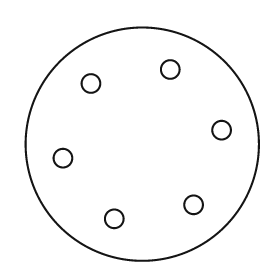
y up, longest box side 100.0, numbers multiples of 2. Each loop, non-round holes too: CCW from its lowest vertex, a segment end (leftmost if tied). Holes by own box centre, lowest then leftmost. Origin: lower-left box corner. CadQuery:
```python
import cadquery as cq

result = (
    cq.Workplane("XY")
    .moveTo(50.0, 50.0)
    .circle(50.0)
    .moveTo(38.0, 18.0)
    .circle(4.0)
    .moveTo(72.0, 24.0)
    .circle(4.0)
    .moveTo(16.0, 44.0)
    .circle(4.0)
    .moveTo(84.0, 56.0)
    .circle(4.0)
    .moveTo(28.0, 76.0)
    .circle(4.0)
    .moveTo(62.0, 82.0)
    .circle(4.0)
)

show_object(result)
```